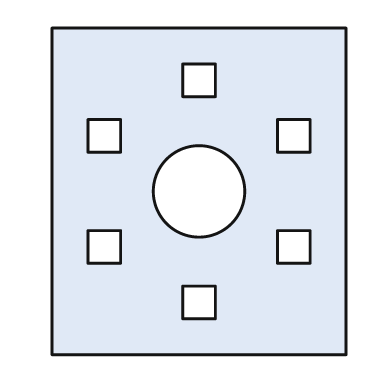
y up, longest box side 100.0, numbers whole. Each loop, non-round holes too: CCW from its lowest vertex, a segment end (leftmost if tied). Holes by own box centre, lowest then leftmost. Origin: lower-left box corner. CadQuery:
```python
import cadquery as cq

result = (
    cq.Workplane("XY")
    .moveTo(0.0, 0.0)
    .lineTo(90.0, 0.0)
    .lineTo(90.0, 100.0)
    .lineTo(0.0, 100.0)
    .close()
    .moveTo(40.0, 11.0)
    .lineTo(50.0, 11.0)
    .lineTo(50.0, 21.0)
    .lineTo(40.0, 21.0)
    .close()
    .moveTo(11.0, 28.0)
    .lineTo(21.0, 28.0)
    .lineTo(21.0, 38.0)
    .lineTo(11.0, 38.0)
    .close()
    .moveTo(69.0, 28.0)
    .lineTo(79.0, 28.0)
    .lineTo(79.0, 38.0)
    .lineTo(69.0, 38.0)
    .close()
    .moveTo(45.0, 50.0)
    .circle(14.0)
    .moveTo(11.0, 62.0)
    .lineTo(21.0, 62.0)
    .lineTo(21.0, 72.0)
    .lineTo(11.0, 72.0)
    .close()
    .moveTo(69.0, 62.0)
    .lineTo(79.0, 62.0)
    .lineTo(79.0, 72.0)
    .lineTo(69.0, 72.0)
    .close()
    .moveTo(40.0, 79.0)
    .lineTo(50.0, 79.0)
    .lineTo(50.0, 89.0)
    .lineTo(40.0, 89.0)
    .close()
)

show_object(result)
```